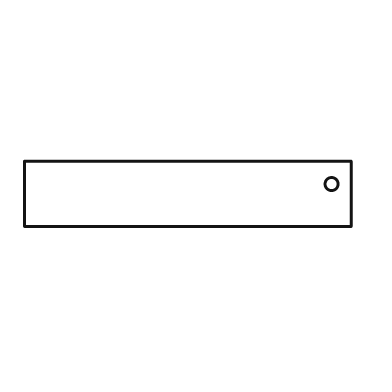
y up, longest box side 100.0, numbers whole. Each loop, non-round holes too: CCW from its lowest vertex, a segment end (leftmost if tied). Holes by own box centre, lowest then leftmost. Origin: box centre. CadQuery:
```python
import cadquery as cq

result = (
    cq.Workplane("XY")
    .moveTo(-50.0, -10.0)
    .lineTo(50.0, -10.0)
    .lineTo(50.0, 10.0)
    .lineTo(-50.0, 10.0)
    .close()
    .moveTo(44.0, 3.0)
    .circle(2.0)
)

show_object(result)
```